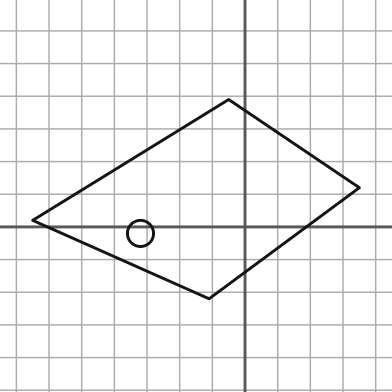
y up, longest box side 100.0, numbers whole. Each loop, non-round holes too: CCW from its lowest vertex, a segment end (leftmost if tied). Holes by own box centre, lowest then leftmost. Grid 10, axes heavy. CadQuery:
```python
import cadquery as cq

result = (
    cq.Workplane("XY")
    .moveTo(-11.0, -22.0)
    .lineTo(35.0, 12.0)
    .lineTo(-5.0, 39.0)
    .lineTo(-65.0, 2.0)
    .close()
    .moveTo(-32.0, -2.0)
    .circle(4.0)
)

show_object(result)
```